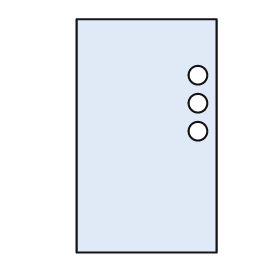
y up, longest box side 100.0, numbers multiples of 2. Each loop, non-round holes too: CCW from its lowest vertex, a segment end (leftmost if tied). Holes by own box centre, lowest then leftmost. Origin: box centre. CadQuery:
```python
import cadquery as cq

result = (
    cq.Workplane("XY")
    .moveTo(-30.0, -50.0)
    .lineTo(30.0, -50.0)
    .lineTo(30.0, 50.0)
    .lineTo(-30.0, 50.0)
    .close()
    .moveTo(22.0, 2.0)
    .circle(4.0)
    .moveTo(22.0, 14.0)
    .circle(4.0)
    .moveTo(22.0, 26.0)
    .circle(4.0)
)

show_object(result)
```